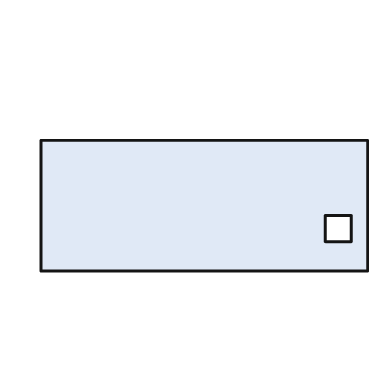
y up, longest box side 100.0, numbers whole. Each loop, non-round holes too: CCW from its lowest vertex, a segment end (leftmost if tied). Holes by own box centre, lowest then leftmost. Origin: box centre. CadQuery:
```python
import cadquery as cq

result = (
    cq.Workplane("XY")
    .moveTo(-50.0, -20.0)
    .lineTo(50.0, -20.0)
    .lineTo(50.0, 20.0)
    .lineTo(-50.0, 20.0)
    .close()
    .moveTo(37.0, -11.0)
    .lineTo(45.0, -11.0)
    .lineTo(45.0, -3.0)
    .lineTo(37.0, -3.0)
    .close()
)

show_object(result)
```